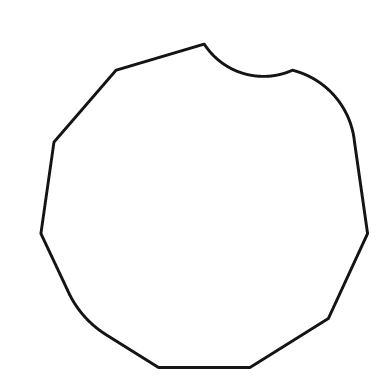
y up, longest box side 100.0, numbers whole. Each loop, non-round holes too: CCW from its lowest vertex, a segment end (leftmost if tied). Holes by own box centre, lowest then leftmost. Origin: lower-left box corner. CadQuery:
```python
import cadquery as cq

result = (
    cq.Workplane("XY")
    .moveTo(36.0, 0.0)
    .lineTo(64.0, 0.0)
    .lineTo(88.0, 15.0)
    .lineTo(100.0, 41.0)
    .lineTo(96.0, 69.0)
    .threePointArc((90.0, 83.0), (77.0, 91.0))
    .threePointArc((62.0, 90.0), (50.0, 99.0))
    .lineTo(23.0, 91.0)
    .lineTo(4.0, 69.0)
    .lineTo(0.0, 41.0)
    .lineTo(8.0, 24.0)
    .threePointArc((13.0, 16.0), (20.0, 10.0))
    .close()
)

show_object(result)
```